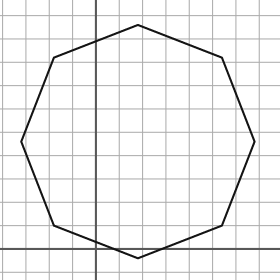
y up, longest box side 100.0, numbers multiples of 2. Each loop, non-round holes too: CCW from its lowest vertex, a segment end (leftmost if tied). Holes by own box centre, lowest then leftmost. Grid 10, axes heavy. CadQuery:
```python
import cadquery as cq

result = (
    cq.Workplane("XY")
    .moveTo(18.0, -4.0)
    .lineTo(54.0, 10.0)
    .lineTo(68.0, 46.0)
    .lineTo(54.0, 82.0)
    .lineTo(18.0, 96.0)
    .lineTo(-18.0, 82.0)
    .lineTo(-32.0, 46.0)
    .lineTo(-18.0, 10.0)
    .close()
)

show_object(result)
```